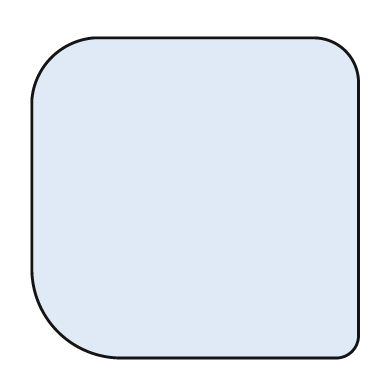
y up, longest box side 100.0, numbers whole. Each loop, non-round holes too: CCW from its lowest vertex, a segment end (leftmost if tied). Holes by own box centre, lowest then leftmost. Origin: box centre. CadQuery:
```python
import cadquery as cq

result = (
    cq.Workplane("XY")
    .moveTo(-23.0, -49.0)
    .lineTo(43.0, -49.0)
    .threePointArc((48.0, -47.0), (50.0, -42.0))
    .lineTo(50.0, 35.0)
    .threePointArc((46.0, 45.0), (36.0, 49.0))
    .lineTo(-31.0, 49.0)
    .threePointArc((-44.0, 43.0), (-50.0, 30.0))
    .lineTo(-50.0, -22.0)
    .threePointArc((-42.0, -41.0), (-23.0, -49.0))
    .close()
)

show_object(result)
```